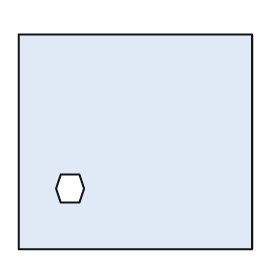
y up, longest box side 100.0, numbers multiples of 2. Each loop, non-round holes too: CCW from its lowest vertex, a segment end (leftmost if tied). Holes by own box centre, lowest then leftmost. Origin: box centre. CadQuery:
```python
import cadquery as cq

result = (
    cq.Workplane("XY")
    .moveTo(-50.0, -46.0)
    .lineTo(50.0, -46.0)
    .lineTo(50.0, 46.0)
    .lineTo(-50.0, 46.0)
    .close()
    .moveTo(-32.0, -26.0)
    .lineTo(-24.0, -26.0)
    .lineTo(-22.0, -20.0)
    .lineTo(-24.0, -14.0)
    .lineTo(-32.0, -14.0)
    .lineTo(-34.0, -20.0)
    .close()
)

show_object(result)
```